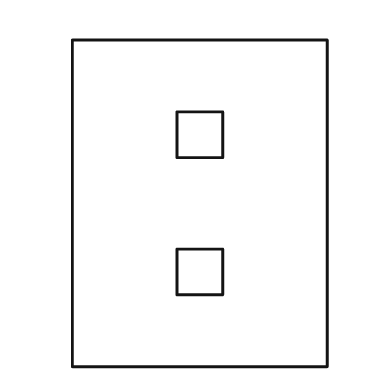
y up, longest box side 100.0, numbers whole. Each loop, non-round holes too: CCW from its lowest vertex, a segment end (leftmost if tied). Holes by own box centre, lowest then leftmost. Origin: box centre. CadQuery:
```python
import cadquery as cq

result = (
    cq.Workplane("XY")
    .moveTo(-39.0, -50.0)
    .lineTo(39.0, -50.0)
    .lineTo(39.0, 50.0)
    .lineTo(-39.0, 50.0)
    .close()
    .moveTo(-7.0, -28.0)
    .lineTo(7.0, -28.0)
    .lineTo(7.0, -14.0)
    .lineTo(-7.0, -14.0)
    .close()
    .moveTo(-7.0, 14.0)
    .lineTo(7.0, 14.0)
    .lineTo(7.0, 28.0)
    .lineTo(-7.0, 28.0)
    .close()
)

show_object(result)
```